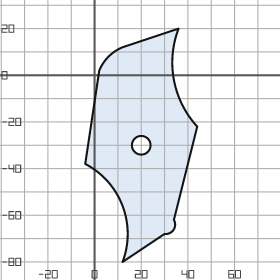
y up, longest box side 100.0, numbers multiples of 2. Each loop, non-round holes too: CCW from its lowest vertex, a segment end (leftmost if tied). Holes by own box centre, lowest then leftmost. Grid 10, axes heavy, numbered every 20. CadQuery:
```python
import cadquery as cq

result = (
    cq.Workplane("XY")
    .moveTo(12.0, -80.0)
    .lineTo(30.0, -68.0)
    .threePointArc((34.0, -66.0), (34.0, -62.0))
    .lineTo(44.0, -22.0)
    .threePointArc((34.0, -2.0), (36.0, 20.0))
    .lineTo(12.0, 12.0)
    .threePointArc((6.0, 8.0), (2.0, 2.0))
    .lineTo(-4.0, -38.0)
    .threePointArc((12.0, -56.0), (12.0, -80.0))
    .close()
    .moveTo(20.0, -30.0)
    .circle(4.0)
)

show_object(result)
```